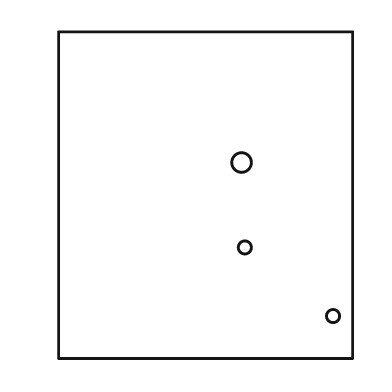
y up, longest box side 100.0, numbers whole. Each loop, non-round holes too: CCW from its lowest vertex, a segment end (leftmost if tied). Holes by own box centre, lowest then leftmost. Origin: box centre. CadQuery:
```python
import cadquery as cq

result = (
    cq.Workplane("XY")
    .moveTo(-45.0, -50.0)
    .lineTo(45.0, -50.0)
    .lineTo(45.0, 50.0)
    .lineTo(-45.0, 50.0)
    .close()
    .moveTo(39.0, -37.0)
    .circle(2.0)
    .moveTo(12.0, -16.0)
    .circle(2.0)
    .moveTo(11.0, 10.0)
    .circle(3.0)
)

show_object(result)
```